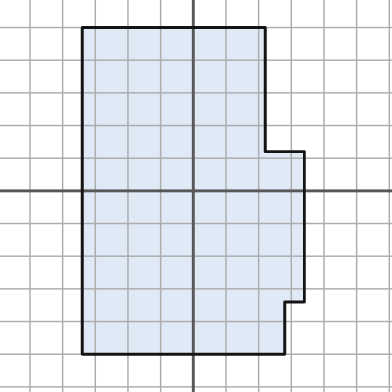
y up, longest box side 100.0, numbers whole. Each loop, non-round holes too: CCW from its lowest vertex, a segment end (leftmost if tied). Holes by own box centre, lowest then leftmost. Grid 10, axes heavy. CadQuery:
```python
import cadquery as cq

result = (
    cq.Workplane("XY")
    .moveTo(-34.0, -50.0)
    .lineTo(28.0, -50.0)
    .lineTo(28.0, -34.0)
    .lineTo(34.0, -34.0)
    .lineTo(34.0, 12.0)
    .lineTo(22.0, 12.0)
    .lineTo(22.0, 50.0)
    .lineTo(-34.0, 50.0)
    .close()
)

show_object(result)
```